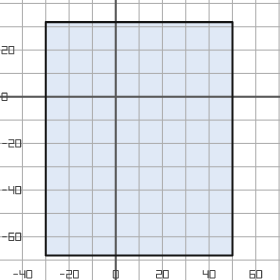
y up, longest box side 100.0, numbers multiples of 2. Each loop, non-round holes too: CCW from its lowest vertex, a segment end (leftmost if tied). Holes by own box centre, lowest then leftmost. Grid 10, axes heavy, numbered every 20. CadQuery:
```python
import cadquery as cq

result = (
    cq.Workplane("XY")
    .moveTo(-30.0, -68.0)
    .lineTo(50.0, -68.0)
    .lineTo(50.0, 32.0)
    .lineTo(-30.0, 32.0)
    .close()
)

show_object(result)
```